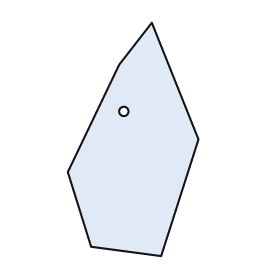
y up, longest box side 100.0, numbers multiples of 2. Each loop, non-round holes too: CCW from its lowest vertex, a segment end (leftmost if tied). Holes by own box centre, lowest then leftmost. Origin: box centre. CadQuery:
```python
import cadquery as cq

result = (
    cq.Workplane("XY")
    .moveTo(12.0, -50.0)
    .lineTo(28.0, 0.0)
    .lineTo(8.0, 50.0)
    .lineTo(-6.0, 32.0)
    .lineTo(-28.0, -14.0)
    .lineTo(-18.0, -46.0)
    .close()
    .moveTo(-4.0, 12.0)
    .circle(2.0)
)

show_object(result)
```